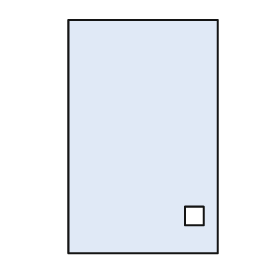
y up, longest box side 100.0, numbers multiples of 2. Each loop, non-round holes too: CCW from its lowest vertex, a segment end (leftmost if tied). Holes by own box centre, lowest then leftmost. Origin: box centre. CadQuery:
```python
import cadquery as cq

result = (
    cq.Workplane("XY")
    .moveTo(-32.0, -50.0)
    .lineTo(32.0, -50.0)
    .lineTo(32.0, 50.0)
    .lineTo(-32.0, 50.0)
    .close()
    .moveTo(18.0, -38.0)
    .lineTo(26.0, -38.0)
    .lineTo(26.0, -30.0)
    .lineTo(18.0, -30.0)
    .close()
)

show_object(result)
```